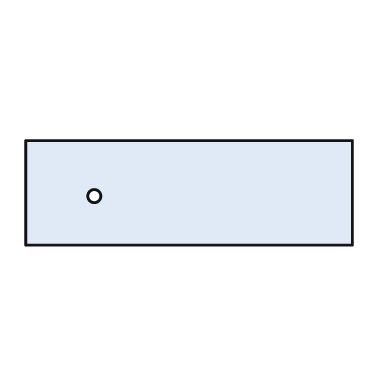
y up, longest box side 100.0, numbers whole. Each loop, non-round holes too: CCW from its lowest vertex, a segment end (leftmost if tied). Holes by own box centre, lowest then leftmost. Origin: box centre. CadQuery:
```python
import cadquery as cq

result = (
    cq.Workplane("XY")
    .moveTo(-50.0, -16.0)
    .lineTo(50.0, -16.0)
    .lineTo(50.0, 16.0)
    .lineTo(-50.0, 16.0)
    .close()
    .moveTo(-29.0, -1.0)
    .circle(2.0)
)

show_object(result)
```